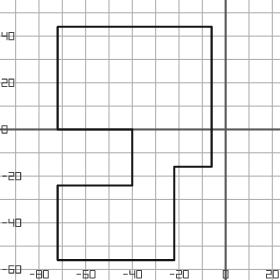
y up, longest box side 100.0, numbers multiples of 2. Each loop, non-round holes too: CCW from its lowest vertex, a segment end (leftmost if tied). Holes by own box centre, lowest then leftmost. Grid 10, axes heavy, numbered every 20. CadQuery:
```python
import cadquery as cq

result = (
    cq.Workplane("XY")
    .moveTo(-72.0, -56.0)
    .lineTo(-22.0, -56.0)
    .lineTo(-22.0, -16.0)
    .lineTo(-6.0, -16.0)
    .lineTo(-6.0, 44.0)
    .lineTo(-72.0, 44.0)
    .lineTo(-72.0, 0.0)
    .lineTo(-40.0, 0.0)
    .lineTo(-40.0, -24.0)
    .lineTo(-72.0, -24.0)
    .close()
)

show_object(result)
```